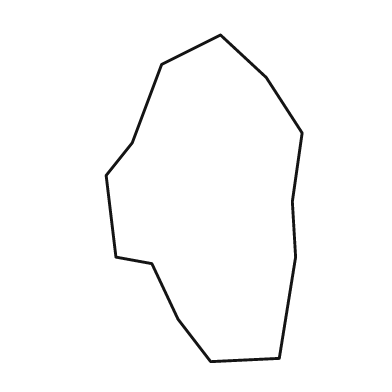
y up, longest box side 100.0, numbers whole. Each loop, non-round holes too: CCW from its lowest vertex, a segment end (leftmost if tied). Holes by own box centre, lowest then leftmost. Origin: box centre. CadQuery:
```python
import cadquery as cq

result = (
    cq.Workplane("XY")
    .moveTo(2.0, -50.0)
    .lineTo(23.0, -49.0)
    .lineTo(28.0, -18.0)
    .lineTo(27.0, -1.0)
    .lineTo(30.0, 20.0)
    .lineTo(19.0, 37.0)
    .lineTo(5.0, 50.0)
    .lineTo(-13.0, 41.0)
    .lineTo(-22.0, 17.0)
    .lineTo(-30.0, 7.0)
    .lineTo(-27.0, -18.0)
    .lineTo(-16.0, -20.0)
    .lineTo(-8.0, -37.0)
    .close()
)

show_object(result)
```